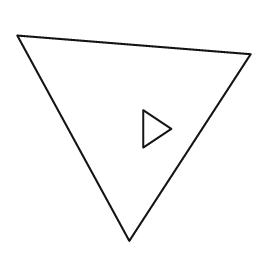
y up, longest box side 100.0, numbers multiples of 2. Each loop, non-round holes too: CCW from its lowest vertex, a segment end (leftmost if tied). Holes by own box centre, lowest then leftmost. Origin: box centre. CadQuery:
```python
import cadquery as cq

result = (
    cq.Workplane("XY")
    .moveTo(-2.0, -44.0)
    .lineTo(50.0, 36.0)
    .lineTo(-50.0, 44.0)
    .close()
    .moveTo(4.0, -4.0)
    .lineTo(16.0, 4.0)
    .lineTo(4.0, 12.0)
    .close()
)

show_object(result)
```